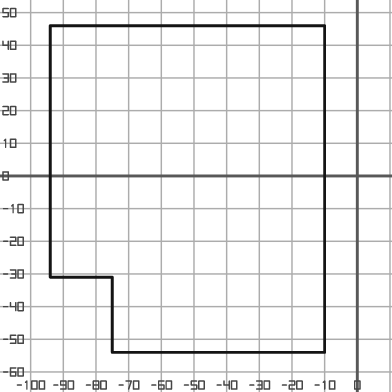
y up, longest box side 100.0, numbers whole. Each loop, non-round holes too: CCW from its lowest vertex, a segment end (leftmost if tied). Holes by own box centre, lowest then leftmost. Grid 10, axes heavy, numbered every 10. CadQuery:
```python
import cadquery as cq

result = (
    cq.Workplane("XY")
    .moveTo(-75.0, -54.0)
    .lineTo(-10.0, -54.0)
    .lineTo(-10.0, 46.0)
    .lineTo(-94.0, 46.0)
    .lineTo(-94.0, -31.0)
    .lineTo(-75.0, -31.0)
    .close()
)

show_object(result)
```